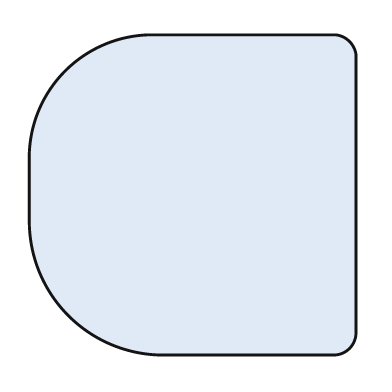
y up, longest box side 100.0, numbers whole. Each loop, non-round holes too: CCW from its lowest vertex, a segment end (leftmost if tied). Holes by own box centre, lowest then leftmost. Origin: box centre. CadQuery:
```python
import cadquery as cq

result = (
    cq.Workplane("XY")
    .moveTo(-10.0, -49.0)
    .lineTo(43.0, -49.0)
    .threePointArc((48.0, -47.0), (50.0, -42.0))
    .lineTo(50.0, 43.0)
    .threePointArc((48.0, 47.0), (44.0, 49.0))
    .lineTo(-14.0, 49.0)
    .threePointArc((-39.0, 38.0), (-50.0, 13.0))
    .lineTo(-50.0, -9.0)
    .threePointArc((-38.0, -37.0), (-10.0, -49.0))
    .close()
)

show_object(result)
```